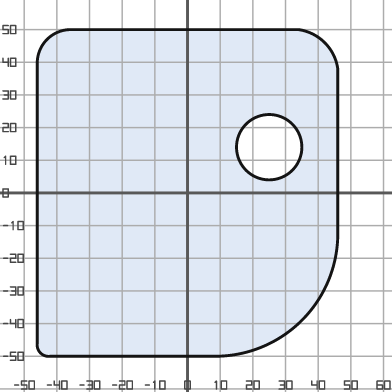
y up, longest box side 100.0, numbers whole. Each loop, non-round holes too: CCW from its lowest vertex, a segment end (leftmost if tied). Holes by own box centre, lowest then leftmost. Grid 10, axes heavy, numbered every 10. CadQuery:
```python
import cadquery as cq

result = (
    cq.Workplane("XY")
    .moveTo(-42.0, -50.0)
    .lineTo(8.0, -50.0)
    .threePointArc((35.0, -39.0), (46.0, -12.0))
    .lineTo(46.0, 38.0)
    .threePointArc((42.0, 46.0), (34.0, 50.0))
    .lineTo(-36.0, 50.0)
    .threePointArc((-43.0, 47.0), (-46.0, 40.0))
    .lineTo(-46.0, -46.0)
    .threePointArc((-45.0, -49.0), (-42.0, -50.0))
    .close()
    .moveTo(25.0, 14.0)
    .circle(10.0)
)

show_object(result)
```